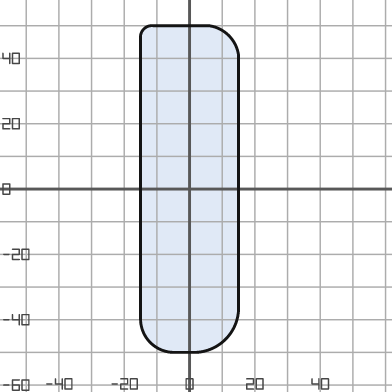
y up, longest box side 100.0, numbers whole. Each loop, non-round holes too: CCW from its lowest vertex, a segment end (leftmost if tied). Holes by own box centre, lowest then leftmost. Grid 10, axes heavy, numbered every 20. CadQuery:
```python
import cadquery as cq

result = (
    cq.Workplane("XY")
    .moveTo(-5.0, -50.0)
    .lineTo(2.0, -50.0)
    .threePointArc((11.0, -46.0), (15.0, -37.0))
    .lineTo(15.0, 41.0)
    .threePointArc((12.0, 47.0), (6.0, 50.0))
    .lineTo(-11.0, 50.0)
    .threePointArc((-14.0, 49.0), (-15.0, 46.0))
    .lineTo(-15.0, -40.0)
    .threePointArc((-12.0, -47.0), (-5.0, -50.0))
    .close()
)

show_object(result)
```